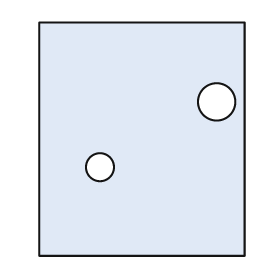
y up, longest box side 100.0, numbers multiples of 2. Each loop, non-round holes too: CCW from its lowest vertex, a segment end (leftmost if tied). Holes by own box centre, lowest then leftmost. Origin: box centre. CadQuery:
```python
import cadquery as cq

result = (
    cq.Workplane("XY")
    .moveTo(-44.0, -50.0)
    .lineTo(44.0, -50.0)
    .lineTo(44.0, 50.0)
    .lineTo(-44.0, 50.0)
    .close()
    .moveTo(-18.0, -12.0)
    .circle(6.0)
    .moveTo(32.0, 16.0)
    .circle(8.0)
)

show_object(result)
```